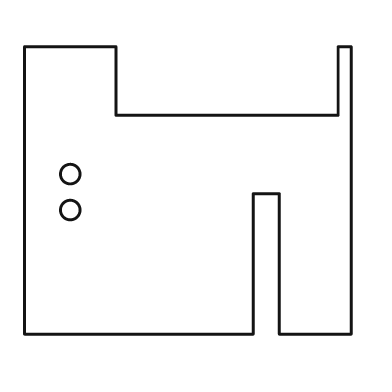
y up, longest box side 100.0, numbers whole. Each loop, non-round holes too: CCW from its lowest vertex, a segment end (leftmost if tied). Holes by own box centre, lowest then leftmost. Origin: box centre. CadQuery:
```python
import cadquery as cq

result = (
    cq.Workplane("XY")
    .moveTo(-50.0, -44.0)
    .lineTo(20.0, -44.0)
    .lineTo(20.0, -1.0)
    .lineTo(28.0, -1.0)
    .lineTo(28.0, -44.0)
    .lineTo(50.0, -44.0)
    .lineTo(50.0, 44.0)
    .lineTo(46.0, 44.0)
    .lineTo(46.0, 23.0)
    .lineTo(-22.0, 23.0)
    .lineTo(-22.0, 44.0)
    .lineTo(-50.0, 44.0)
    .close()
    .moveTo(-36.0, -6.0)
    .circle(3.0)
    .moveTo(-36.0, 5.0)
    .circle(3.0)
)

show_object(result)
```